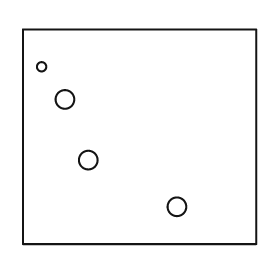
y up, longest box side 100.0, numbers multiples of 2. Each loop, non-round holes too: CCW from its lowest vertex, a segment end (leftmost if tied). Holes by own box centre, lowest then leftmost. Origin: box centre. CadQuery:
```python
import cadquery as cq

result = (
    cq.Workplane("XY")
    .moveTo(-50.0, -46.0)
    .lineTo(50.0, -46.0)
    .lineTo(50.0, 46.0)
    .lineTo(-50.0, 46.0)
    .close()
    .moveTo(16.0, -30.0)
    .circle(4.0)
    .moveTo(-22.0, -10.0)
    .circle(4.0)
    .moveTo(-32.0, 16.0)
    .circle(4.0)
    .moveTo(-42.0, 30.0)
    .circle(2.0)
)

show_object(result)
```